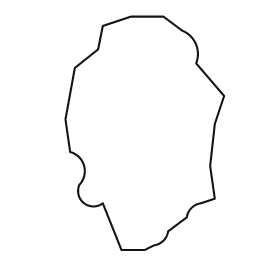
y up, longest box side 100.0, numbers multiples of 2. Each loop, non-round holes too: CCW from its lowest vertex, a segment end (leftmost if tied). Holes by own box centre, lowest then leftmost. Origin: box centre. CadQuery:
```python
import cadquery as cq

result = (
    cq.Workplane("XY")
    .moveTo(-10.0, -50.0)
    .lineTo(0.0, -50.0)
    .lineTo(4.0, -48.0)
    .threePointArc((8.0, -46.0), (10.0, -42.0))
    .lineTo(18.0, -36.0)
    .threePointArc((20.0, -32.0), (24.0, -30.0))
    .lineTo(30.0, -28.0)
    .lineTo(28.0, -14.0)
    .lineTo(30.0, 4.0)
    .lineTo(34.0, 16.0)
    .lineTo(22.0, 30.0)
    .threePointArc((22.0, 38.0), (16.0, 44.0))
    .lineTo(8.0, 50.0)
    .lineTo(-6.0, 50.0)
    .lineTo(-18.0, 46.0)
    .lineTo(-20.0, 36.0)
    .lineTo(-30.0, 28.0)
    .lineTo(-34.0, 6.0)
    .lineTo(-32.0, -8.0)
    .threePointArc((-26.0, -14.0), (-28.0, -22.0))
    .threePointArc((-26.0, -30.0), (-18.0, -30.0))
    .close()
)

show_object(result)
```